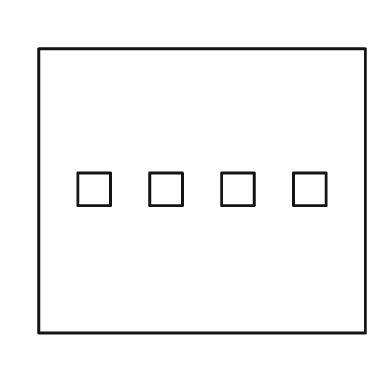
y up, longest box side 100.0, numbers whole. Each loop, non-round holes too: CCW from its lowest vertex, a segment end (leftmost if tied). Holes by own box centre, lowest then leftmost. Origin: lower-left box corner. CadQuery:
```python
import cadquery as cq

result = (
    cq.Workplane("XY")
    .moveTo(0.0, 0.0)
    .lineTo(100.0, 0.0)
    .lineTo(100.0, 87.0)
    .lineTo(0.0, 87.0)
    .close()
    .moveTo(12.0, 39.0)
    .lineTo(22.0, 39.0)
    .lineTo(22.0, 49.0)
    .lineTo(12.0, 49.0)
    .close()
    .moveTo(34.0, 39.0)
    .lineTo(44.0, 39.0)
    .lineTo(44.0, 49.0)
    .lineTo(34.0, 49.0)
    .close()
    .moveTo(56.0, 39.0)
    .lineTo(66.0, 39.0)
    .lineTo(66.0, 49.0)
    .lineTo(56.0, 49.0)
    .close()
    .moveTo(78.0, 39.0)
    .lineTo(88.0, 39.0)
    .lineTo(88.0, 49.0)
    .lineTo(78.0, 49.0)
    .close()
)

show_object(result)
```